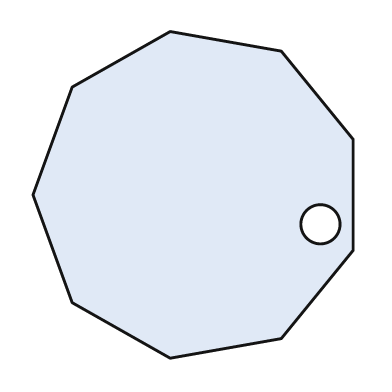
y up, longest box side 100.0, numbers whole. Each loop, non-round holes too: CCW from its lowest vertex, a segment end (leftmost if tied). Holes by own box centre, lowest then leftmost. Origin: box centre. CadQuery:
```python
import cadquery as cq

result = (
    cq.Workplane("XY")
    .moveTo(-7.0, -50.0)
    .lineTo(27.0, -44.0)
    .lineTo(49.0, -17.0)
    .lineTo(49.0, 17.0)
    .lineTo(27.0, 44.0)
    .lineTo(-7.0, 50.0)
    .lineTo(-37.0, 33.0)
    .lineTo(-49.0, 0.0)
    .lineTo(-37.0, -33.0)
    .close()
    .moveTo(39.0, -9.0)
    .circle(6.0)
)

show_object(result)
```